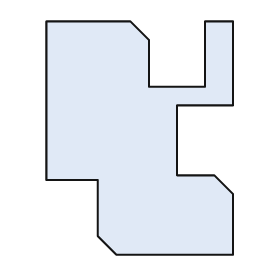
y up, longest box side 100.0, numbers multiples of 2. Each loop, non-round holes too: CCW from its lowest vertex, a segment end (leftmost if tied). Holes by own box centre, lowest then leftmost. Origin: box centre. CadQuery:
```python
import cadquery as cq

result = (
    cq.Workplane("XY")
    .moveTo(-10.0, -50.0)
    .lineTo(40.0, -50.0)
    .lineTo(40.0, -24.0)
    .lineTo(32.0, -16.0)
    .lineTo(16.0, -16.0)
    .lineTo(16.0, 14.0)
    .lineTo(40.0, 14.0)
    .lineTo(40.0, 50.0)
    .lineTo(28.0, 50.0)
    .lineTo(28.0, 22.0)
    .lineTo(4.0, 22.0)
    .lineTo(4.0, 42.0)
    .lineTo(-4.0, 50.0)
    .lineTo(-40.0, 50.0)
    .lineTo(-40.0, -18.0)
    .lineTo(-18.0, -18.0)
    .lineTo(-18.0, -42.0)
    .close()
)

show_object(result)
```